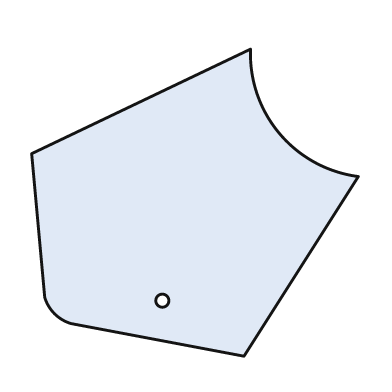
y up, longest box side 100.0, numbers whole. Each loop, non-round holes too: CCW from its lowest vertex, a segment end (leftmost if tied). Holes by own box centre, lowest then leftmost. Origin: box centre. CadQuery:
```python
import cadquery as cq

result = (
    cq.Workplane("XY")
    .moveTo(15.0, -47.0)
    .lineTo(50.0, 8.0)
    .threePointArc((26.0, 21.0), (17.0, 47.0))
    .lineTo(-50.0, 15.0)
    .lineTo(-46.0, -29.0)
    .threePointArc((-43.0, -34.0), (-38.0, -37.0))
    .close()
    .moveTo(-10.0, -30.0)
    .circle(2.0)
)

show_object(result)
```